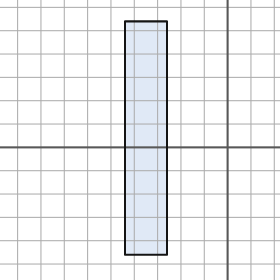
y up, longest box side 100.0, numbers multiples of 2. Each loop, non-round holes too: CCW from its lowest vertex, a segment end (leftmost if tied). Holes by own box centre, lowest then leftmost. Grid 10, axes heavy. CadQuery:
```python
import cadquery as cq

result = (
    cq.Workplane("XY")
    .moveTo(-44.0, -46.0)
    .lineTo(-26.0, -46.0)
    .lineTo(-26.0, 54.0)
    .lineTo(-44.0, 54.0)
    .close()
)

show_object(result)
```